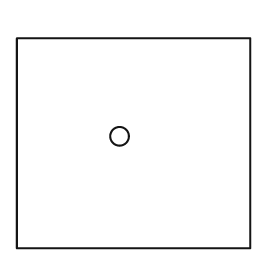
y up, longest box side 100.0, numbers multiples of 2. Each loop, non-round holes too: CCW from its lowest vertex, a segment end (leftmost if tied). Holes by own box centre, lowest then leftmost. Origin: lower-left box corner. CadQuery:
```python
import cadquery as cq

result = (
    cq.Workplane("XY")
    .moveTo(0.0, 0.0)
    .lineTo(100.0, 0.0)
    .lineTo(100.0, 90.0)
    .lineTo(0.0, 90.0)
    .close()
    .moveTo(44.0, 48.0)
    .circle(4.0)
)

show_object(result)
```